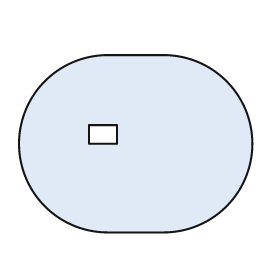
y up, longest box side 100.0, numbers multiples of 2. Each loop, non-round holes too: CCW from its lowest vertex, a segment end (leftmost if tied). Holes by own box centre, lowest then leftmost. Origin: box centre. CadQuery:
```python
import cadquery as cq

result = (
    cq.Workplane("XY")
    .moveTo(-12.0, -38.0)
    .lineTo(12.0, -38.0)
    .threePointArc((50.0, 0.0), (12.0, 38.0))
    .lineTo(-12.0, 38.0)
    .threePointArc((-50.0, 0.0), (-12.0, -38.0))
    .close()
    .moveTo(-20.0, 0.0)
    .lineTo(-8.0, 0.0)
    .lineTo(-8.0, 8.0)
    .lineTo(-20.0, 8.0)
    .close()
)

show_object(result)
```